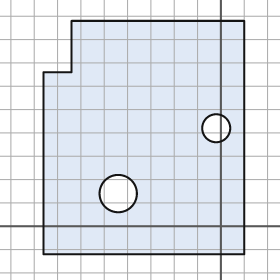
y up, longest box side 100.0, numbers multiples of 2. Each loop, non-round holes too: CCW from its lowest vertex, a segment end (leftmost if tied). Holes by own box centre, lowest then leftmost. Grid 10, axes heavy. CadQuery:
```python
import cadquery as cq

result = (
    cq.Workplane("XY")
    .moveTo(-76.0, -12.0)
    .lineTo(10.0, -12.0)
    .lineTo(10.0, 88.0)
    .lineTo(-64.0, 88.0)
    .lineTo(-64.0, 66.0)
    .lineTo(-76.0, 66.0)
    .close()
    .moveTo(-44.0, 14.0)
    .circle(8.0)
    .moveTo(-2.0, 42.0)
    .circle(6.0)
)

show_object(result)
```